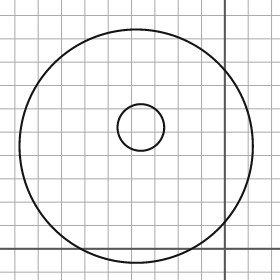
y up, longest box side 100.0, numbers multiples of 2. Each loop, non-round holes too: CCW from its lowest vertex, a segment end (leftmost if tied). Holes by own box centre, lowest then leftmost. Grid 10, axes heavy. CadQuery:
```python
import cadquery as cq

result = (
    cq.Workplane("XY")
    .moveTo(-38.0, 44.0)
    .circle(50.0)
    .moveTo(-36.0, 52.0)
    .circle(10.0)
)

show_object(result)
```